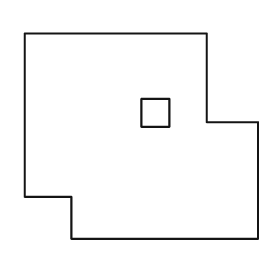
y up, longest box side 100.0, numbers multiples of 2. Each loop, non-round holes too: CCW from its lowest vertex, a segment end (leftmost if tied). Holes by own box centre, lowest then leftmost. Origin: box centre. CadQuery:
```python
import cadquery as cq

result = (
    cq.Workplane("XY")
    .moveTo(-30.0, -44.0)
    .lineTo(50.0, -44.0)
    .lineTo(50.0, 6.0)
    .lineTo(28.0, 6.0)
    .lineTo(28.0, 44.0)
    .lineTo(-50.0, 44.0)
    .lineTo(-50.0, -26.0)
    .lineTo(-30.0, -26.0)
    .close()
    .moveTo(0.0, 4.0)
    .lineTo(12.0, 4.0)
    .lineTo(12.0, 16.0)
    .lineTo(0.0, 16.0)
    .close()
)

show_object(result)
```